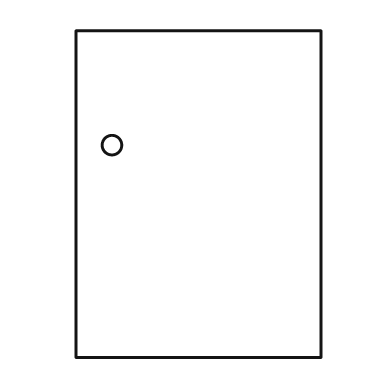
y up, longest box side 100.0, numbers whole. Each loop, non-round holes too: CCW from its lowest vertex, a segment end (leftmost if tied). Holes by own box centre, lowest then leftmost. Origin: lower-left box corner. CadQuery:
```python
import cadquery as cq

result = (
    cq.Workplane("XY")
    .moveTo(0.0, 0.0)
    .lineTo(75.0, 0.0)
    .lineTo(75.0, 100.0)
    .lineTo(0.0, 100.0)
    .close()
    .moveTo(11.0, 65.0)
    .circle(3.0)
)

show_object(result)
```